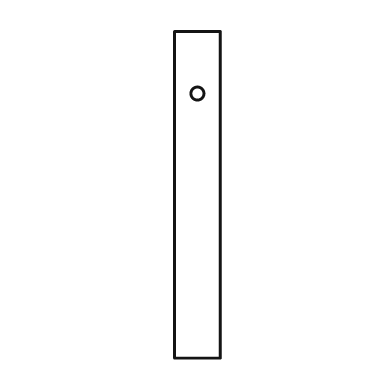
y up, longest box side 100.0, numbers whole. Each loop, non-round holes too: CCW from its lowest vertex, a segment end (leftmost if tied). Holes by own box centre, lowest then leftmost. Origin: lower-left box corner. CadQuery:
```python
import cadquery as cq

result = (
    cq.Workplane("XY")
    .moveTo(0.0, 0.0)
    .lineTo(14.0, 0.0)
    .lineTo(14.0, 100.0)
    .lineTo(0.0, 100.0)
    .close()
    .moveTo(7.0, 81.0)
    .circle(2.0)
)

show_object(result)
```